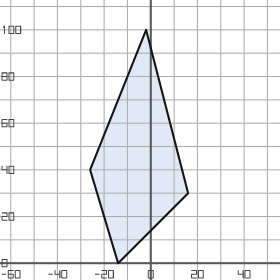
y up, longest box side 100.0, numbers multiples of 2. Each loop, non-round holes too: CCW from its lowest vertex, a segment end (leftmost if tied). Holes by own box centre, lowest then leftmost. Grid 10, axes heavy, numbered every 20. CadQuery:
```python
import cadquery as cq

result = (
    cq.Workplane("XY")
    .moveTo(-14.0, 0.0)
    .lineTo(16.0, 30.0)
    .lineTo(-2.0, 100.0)
    .lineTo(-26.0, 40.0)
    .close()
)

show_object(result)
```